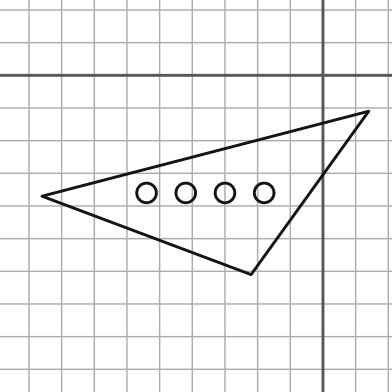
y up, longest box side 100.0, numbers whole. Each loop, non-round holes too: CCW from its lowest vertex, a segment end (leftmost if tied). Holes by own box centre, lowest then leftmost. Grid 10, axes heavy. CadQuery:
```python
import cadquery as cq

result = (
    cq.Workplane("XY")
    .moveTo(-22.0, -61.0)
    .lineTo(14.0, -11.0)
    .lineTo(-86.0, -37.0)
    .close()
    .moveTo(-54.0, -36.0)
    .circle(3.0)
    .moveTo(-42.0, -36.0)
    .circle(3.0)
    .moveTo(-30.0, -36.0)
    .circle(3.0)
    .moveTo(-18.0, -36.0)
    .circle(3.0)
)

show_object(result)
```